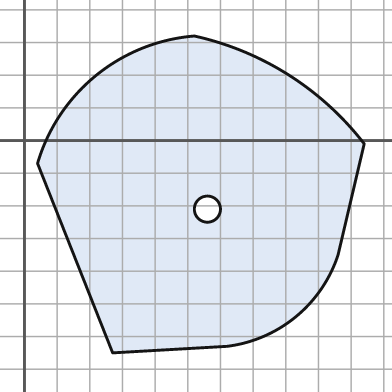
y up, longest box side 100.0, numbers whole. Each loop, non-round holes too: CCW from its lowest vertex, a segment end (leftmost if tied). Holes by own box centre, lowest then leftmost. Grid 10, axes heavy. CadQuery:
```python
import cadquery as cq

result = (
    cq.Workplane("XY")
    .moveTo(27.0, -65.0)
    .lineTo(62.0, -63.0)
    .threePointArc((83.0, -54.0), (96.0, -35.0))
    .lineTo(104.0, -1.0)
    .threePointArc((81.0, 20.0), (52.0, 32.0))
    .threePointArc((22.0, 20.0), (4.0, -7.0))
    .close()
    .moveTo(56.0, -21.0)
    .circle(4.0)
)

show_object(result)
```